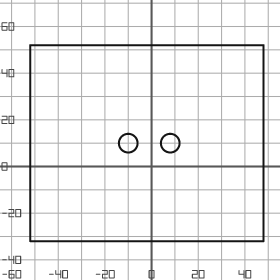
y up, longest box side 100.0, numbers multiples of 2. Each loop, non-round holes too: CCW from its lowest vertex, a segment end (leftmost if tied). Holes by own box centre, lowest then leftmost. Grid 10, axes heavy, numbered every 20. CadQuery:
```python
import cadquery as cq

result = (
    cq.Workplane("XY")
    .moveTo(-52.0, -32.0)
    .lineTo(48.0, -32.0)
    .lineTo(48.0, 52.0)
    .lineTo(-52.0, 52.0)
    .close()
    .moveTo(-10.0, 10.0)
    .circle(4.0)
    .moveTo(8.0, 10.0)
    .circle(4.0)
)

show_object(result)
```